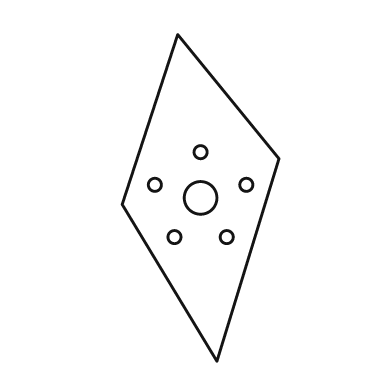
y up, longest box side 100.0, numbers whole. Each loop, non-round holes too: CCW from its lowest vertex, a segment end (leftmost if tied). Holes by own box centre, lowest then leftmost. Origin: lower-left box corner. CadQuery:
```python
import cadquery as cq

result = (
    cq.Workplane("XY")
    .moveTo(29.0, 0.0)
    .lineTo(48.0, 62.0)
    .lineTo(17.0, 100.0)
    .lineTo(0.0, 48.0)
    .close()
    .moveTo(16.0, 38.0)
    .circle(2.0)
    .moveTo(32.0, 38.0)
    .circle(2.0)
    .moveTo(24.0, 50.0)
    .circle(5.0)
    .moveTo(10.0, 54.0)
    .circle(2.0)
    .moveTo(38.0, 54.0)
    .circle(2.0)
    .moveTo(24.0, 64.0)
    .circle(2.0)
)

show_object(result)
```